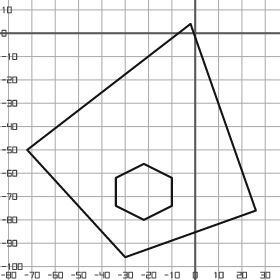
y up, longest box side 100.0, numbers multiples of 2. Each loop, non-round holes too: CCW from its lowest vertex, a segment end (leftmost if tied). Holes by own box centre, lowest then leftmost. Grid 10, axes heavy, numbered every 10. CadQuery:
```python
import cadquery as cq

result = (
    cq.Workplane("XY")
    .moveTo(-30.0, -96.0)
    .lineTo(26.0, -76.0)
    .lineTo(-2.0, 4.0)
    .lineTo(-72.0, -50.0)
    .close()
    .moveTo(-22.0, -80.0)
    .lineTo(-10.0, -74.0)
    .lineTo(-10.0, -62.0)
    .lineTo(-22.0, -56.0)
    .lineTo(-34.0, -62.0)
    .lineTo(-34.0, -74.0)
    .close()
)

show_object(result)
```